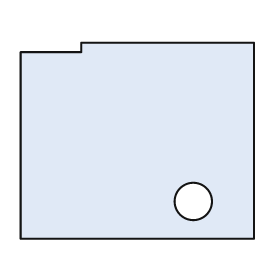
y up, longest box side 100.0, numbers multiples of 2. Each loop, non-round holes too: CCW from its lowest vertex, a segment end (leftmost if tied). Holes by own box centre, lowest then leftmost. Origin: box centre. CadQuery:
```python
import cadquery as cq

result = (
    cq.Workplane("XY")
    .moveTo(-50.0, -42.0)
    .lineTo(50.0, -42.0)
    .lineTo(50.0, 42.0)
    .lineTo(-24.0, 42.0)
    .lineTo(-24.0, 38.0)
    .lineTo(-50.0, 38.0)
    .close()
    .moveTo(24.0, -26.0)
    .circle(8.0)
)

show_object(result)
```